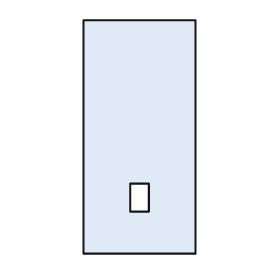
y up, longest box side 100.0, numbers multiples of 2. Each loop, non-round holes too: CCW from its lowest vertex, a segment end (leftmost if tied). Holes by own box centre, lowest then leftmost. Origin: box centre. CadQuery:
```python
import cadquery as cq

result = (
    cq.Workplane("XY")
    .moveTo(-24.0, -50.0)
    .lineTo(24.0, -50.0)
    .lineTo(24.0, 50.0)
    .lineTo(-24.0, 50.0)
    .close()
    .moveTo(-4.0, -32.0)
    .lineTo(4.0, -32.0)
    .lineTo(4.0, -20.0)
    .lineTo(-4.0, -20.0)
    .close()
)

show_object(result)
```